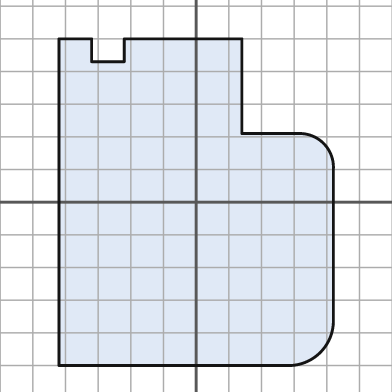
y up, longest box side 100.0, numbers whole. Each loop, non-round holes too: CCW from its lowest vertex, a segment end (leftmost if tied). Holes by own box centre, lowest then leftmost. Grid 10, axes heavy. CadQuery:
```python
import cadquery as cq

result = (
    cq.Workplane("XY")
    .moveTo(-42.0, -50.0)
    .lineTo(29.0, -50.0)
    .threePointArc((38.0, -46.0), (42.0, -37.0))
    .lineTo(42.0, 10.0)
    .threePointArc((39.0, 18.0), (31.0, 21.0))
    .lineTo(14.0, 21.0)
    .lineTo(14.0, 50.0)
    .lineTo(-22.0, 50.0)
    .lineTo(-22.0, 43.0)
    .lineTo(-32.0, 43.0)
    .lineTo(-32.0, 50.0)
    .lineTo(-42.0, 50.0)
    .close()
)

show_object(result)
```